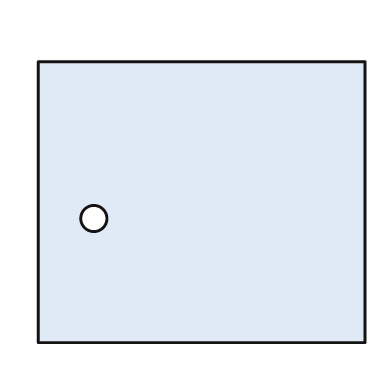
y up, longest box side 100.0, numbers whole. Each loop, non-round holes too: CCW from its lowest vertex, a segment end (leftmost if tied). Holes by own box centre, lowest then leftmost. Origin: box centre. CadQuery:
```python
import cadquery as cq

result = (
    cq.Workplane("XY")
    .moveTo(-50.0, -43.0)
    .lineTo(50.0, -43.0)
    .lineTo(50.0, 43.0)
    .lineTo(-50.0, 43.0)
    .close()
    .moveTo(-33.0, -5.0)
    .circle(4.0)
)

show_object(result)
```